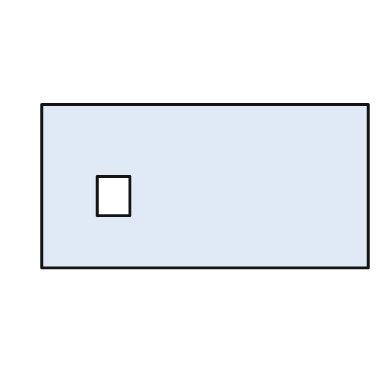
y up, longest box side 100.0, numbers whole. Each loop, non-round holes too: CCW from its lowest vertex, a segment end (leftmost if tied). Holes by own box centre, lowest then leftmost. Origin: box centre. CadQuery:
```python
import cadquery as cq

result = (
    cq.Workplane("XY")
    .moveTo(-50.0, -25.0)
    .lineTo(50.0, -25.0)
    .lineTo(50.0, 25.0)
    .lineTo(-50.0, 25.0)
    .close()
    .moveTo(-33.0, -9.0)
    .lineTo(-23.0, -9.0)
    .lineTo(-23.0, 3.0)
    .lineTo(-33.0, 3.0)
    .close()
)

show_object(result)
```